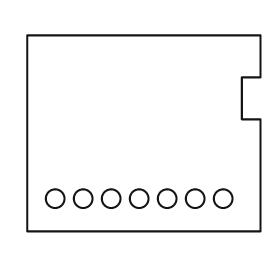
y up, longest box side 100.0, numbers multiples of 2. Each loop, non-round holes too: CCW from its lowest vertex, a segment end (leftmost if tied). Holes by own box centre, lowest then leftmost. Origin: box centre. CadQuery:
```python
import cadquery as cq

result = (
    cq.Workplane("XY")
    .moveTo(-50.0, -42.0)
    .lineTo(50.0, -42.0)
    .lineTo(50.0, 6.0)
    .lineTo(42.0, 6.0)
    .lineTo(42.0, 24.0)
    .lineTo(50.0, 24.0)
    .lineTo(50.0, 42.0)
    .lineTo(-50.0, 42.0)
    .close()
    .moveTo(-38.0, -28.0)
    .circle(4.0)
    .moveTo(-26.0, -28.0)
    .circle(4.0)
    .moveTo(-14.0, -28.0)
    .circle(4.0)
    .moveTo(-2.0, -28.0)
    .circle(4.0)
    .moveTo(10.0, -28.0)
    .circle(4.0)
    .moveTo(22.0, -28.0)
    .circle(4.0)
    .moveTo(34.0, -28.0)
    .circle(4.0)
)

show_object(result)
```